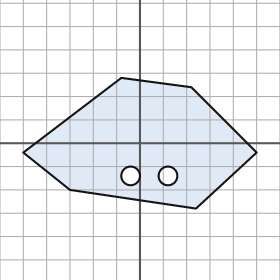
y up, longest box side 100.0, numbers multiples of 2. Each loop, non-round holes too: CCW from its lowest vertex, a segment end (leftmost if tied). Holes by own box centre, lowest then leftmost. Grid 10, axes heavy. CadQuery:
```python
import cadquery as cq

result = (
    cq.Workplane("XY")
    .moveTo(24.0, -28.0)
    .lineTo(50.0, -4.0)
    .lineTo(22.0, 24.0)
    .lineTo(-8.0, 28.0)
    .lineTo(-50.0, -4.0)
    .lineTo(-30.0, -20.0)
    .close()
    .moveTo(-4.0, -14.0)
    .circle(4.0)
    .moveTo(12.0, -14.0)
    .circle(4.0)
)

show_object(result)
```